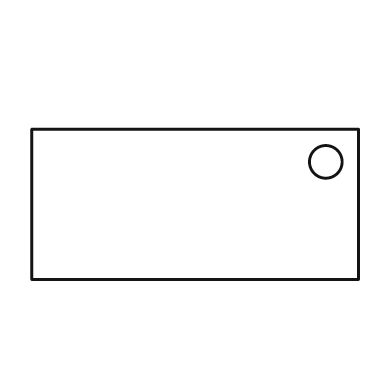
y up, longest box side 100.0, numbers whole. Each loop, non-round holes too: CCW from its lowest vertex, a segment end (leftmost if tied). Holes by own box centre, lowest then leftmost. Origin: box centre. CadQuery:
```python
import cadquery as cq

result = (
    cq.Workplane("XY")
    .moveTo(-50.0, -23.0)
    .lineTo(50.0, -23.0)
    .lineTo(50.0, 23.0)
    .lineTo(-50.0, 23.0)
    .close()
    .moveTo(40.0, 13.0)
    .circle(5.0)
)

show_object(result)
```